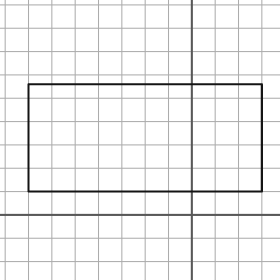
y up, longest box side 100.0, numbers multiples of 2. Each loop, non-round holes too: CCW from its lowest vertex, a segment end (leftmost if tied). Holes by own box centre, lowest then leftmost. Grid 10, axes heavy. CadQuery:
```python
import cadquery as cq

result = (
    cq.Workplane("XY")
    .moveTo(-70.0, 10.0)
    .lineTo(30.0, 10.0)
    .lineTo(30.0, 56.0)
    .lineTo(-70.0, 56.0)
    .close()
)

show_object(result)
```